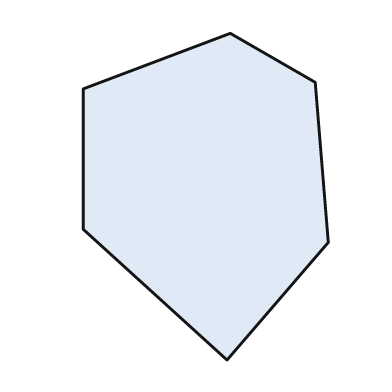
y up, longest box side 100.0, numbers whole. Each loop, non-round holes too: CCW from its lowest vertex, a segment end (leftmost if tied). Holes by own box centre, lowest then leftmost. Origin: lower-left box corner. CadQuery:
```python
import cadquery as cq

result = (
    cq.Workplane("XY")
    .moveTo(44.0, 0.0)
    .lineTo(75.0, 36.0)
    .lineTo(71.0, 85.0)
    .lineTo(45.0, 100.0)
    .lineTo(0.0, 83.0)
    .lineTo(0.0, 40.0)
    .close()
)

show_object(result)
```